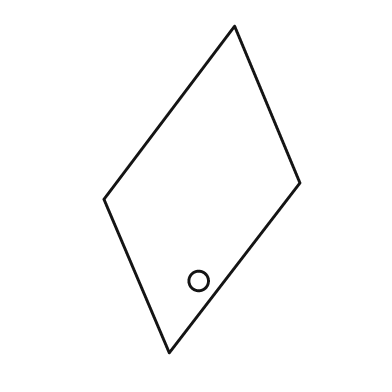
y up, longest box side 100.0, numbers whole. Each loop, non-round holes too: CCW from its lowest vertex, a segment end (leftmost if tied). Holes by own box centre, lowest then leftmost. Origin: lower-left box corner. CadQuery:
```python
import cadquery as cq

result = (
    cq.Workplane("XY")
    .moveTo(20.0, 0.0)
    .lineTo(60.0, 52.0)
    .lineTo(40.0, 100.0)
    .lineTo(0.0, 47.0)
    .close()
    .moveTo(29.0, 22.0)
    .circle(3.0)
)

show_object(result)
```